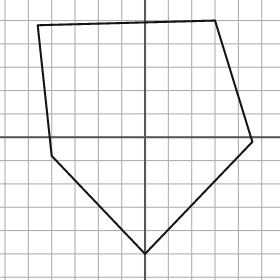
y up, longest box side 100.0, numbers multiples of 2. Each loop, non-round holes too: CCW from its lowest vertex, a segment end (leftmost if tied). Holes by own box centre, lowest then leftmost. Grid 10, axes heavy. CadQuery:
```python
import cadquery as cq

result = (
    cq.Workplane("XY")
    .moveTo(0.0, -50.0)
    .lineTo(46.0, -2.0)
    .lineTo(30.0, 50.0)
    .lineTo(-46.0, 48.0)
    .lineTo(-40.0, -8.0)
    .close()
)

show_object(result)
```